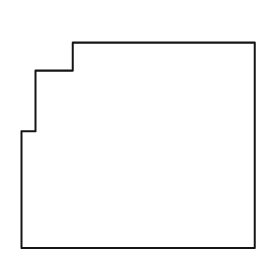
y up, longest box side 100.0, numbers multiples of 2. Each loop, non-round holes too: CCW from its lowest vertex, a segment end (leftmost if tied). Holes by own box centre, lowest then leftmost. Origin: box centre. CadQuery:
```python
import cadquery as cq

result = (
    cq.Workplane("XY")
    .moveTo(-50.0, -44.0)
    .lineTo(50.0, -44.0)
    .lineTo(50.0, 44.0)
    .lineTo(-28.0, 44.0)
    .lineTo(-28.0, 32.0)
    .lineTo(-44.0, 32.0)
    .lineTo(-44.0, 6.0)
    .lineTo(-50.0, 6.0)
    .close()
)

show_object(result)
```